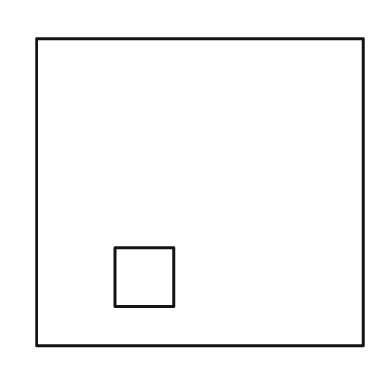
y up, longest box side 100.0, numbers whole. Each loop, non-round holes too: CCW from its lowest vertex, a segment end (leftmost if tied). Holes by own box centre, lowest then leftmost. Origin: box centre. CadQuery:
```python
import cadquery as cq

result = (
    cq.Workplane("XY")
    .moveTo(-50.0, -47.0)
    .lineTo(50.0, -47.0)
    .lineTo(50.0, 47.0)
    .lineTo(-50.0, 47.0)
    .close()
    .moveTo(-26.0, -35.0)
    .lineTo(-8.0, -35.0)
    .lineTo(-8.0, -17.0)
    .lineTo(-26.0, -17.0)
    .close()
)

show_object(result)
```